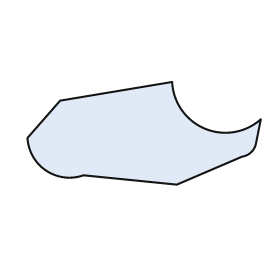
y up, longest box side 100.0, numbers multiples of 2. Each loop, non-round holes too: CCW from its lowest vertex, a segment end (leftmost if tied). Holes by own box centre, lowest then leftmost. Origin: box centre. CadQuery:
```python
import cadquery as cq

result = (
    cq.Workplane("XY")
    .moveTo(14.0, -22.0)
    .lineTo(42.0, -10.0)
    .threePointArc((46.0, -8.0), (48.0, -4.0))
    .lineTo(50.0, 6.0)
    .threePointArc((26.0, 2.0), (12.0, 22.0))
    .lineTo(-36.0, 14.0)
    .lineTo(-50.0, -2.0)
    .threePointArc((-42.0, -16.0), (-26.0, -18.0))
    .close()
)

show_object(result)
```